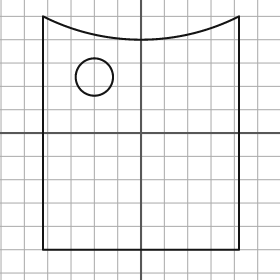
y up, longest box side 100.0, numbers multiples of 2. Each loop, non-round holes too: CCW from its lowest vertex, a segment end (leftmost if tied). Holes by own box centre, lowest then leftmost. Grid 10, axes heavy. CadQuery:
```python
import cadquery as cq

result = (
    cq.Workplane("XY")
    .moveTo(-42.0, -50.0)
    .lineTo(42.0, -50.0)
    .lineTo(42.0, 50.0)
    .threePointArc((0.0, 40.0), (-42.0, 50.0))
    .close()
    .moveTo(-20.0, 24.0)
    .circle(8.0)
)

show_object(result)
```